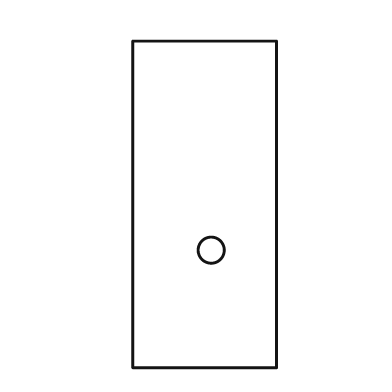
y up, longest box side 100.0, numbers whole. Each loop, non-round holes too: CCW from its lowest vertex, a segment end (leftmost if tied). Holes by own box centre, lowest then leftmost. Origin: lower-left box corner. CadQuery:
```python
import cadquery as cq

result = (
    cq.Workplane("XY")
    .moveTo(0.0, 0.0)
    .lineTo(44.0, 0.0)
    .lineTo(44.0, 100.0)
    .lineTo(0.0, 100.0)
    .close()
    .moveTo(24.0, 36.0)
    .circle(4.0)
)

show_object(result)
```